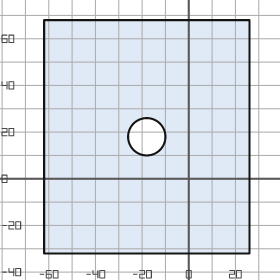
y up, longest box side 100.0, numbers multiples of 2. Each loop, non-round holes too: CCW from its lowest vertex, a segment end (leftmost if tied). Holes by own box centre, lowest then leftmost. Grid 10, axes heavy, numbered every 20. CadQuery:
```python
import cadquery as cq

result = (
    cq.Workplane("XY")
    .moveTo(-62.0, -32.0)
    .lineTo(26.0, -32.0)
    .lineTo(26.0, 68.0)
    .lineTo(-62.0, 68.0)
    .close()
    .moveTo(-18.0, 18.0)
    .circle(8.0)
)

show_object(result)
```